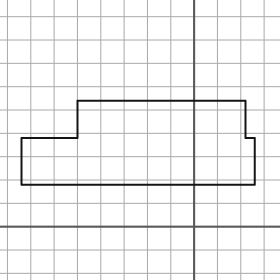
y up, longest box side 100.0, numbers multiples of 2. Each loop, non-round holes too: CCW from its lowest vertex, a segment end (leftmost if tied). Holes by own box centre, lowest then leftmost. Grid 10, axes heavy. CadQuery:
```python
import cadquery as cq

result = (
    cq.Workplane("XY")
    .moveTo(-74.0, 18.0)
    .lineTo(26.0, 18.0)
    .lineTo(26.0, 38.0)
    .lineTo(22.0, 38.0)
    .lineTo(22.0, 54.0)
    .lineTo(-50.0, 54.0)
    .lineTo(-50.0, 38.0)
    .lineTo(-74.0, 38.0)
    .close()
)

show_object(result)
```